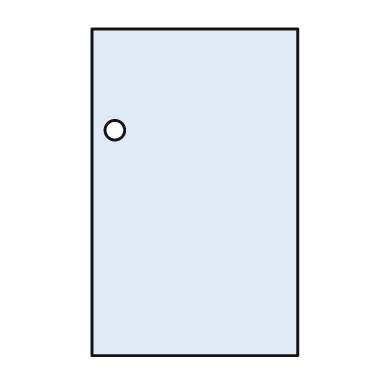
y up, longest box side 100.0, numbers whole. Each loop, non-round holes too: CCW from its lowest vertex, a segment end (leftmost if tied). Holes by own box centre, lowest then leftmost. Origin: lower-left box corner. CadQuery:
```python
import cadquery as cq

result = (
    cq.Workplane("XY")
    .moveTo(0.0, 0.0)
    .lineTo(63.0, 0.0)
    .lineTo(63.0, 100.0)
    .lineTo(0.0, 100.0)
    .close()
    .moveTo(7.0, 69.0)
    .circle(3.0)
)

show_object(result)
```